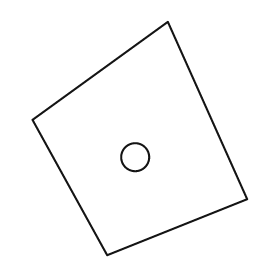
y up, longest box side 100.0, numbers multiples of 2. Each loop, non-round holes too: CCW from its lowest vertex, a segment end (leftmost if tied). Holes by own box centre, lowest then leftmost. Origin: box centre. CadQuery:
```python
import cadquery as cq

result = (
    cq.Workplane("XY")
    .moveTo(-14.0, -50.0)
    .lineTo(46.0, -26.0)
    .lineTo(12.0, 50.0)
    .lineTo(-46.0, 8.0)
    .close()
    .moveTo(-2.0, -8.0)
    .circle(6.0)
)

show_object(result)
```